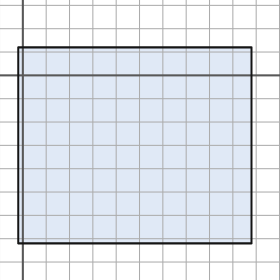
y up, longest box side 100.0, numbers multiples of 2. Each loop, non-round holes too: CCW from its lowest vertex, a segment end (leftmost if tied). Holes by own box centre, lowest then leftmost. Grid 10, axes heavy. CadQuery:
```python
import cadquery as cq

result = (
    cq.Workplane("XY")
    .moveTo(-2.0, -72.0)
    .lineTo(98.0, -72.0)
    .lineTo(98.0, 12.0)
    .lineTo(-2.0, 12.0)
    .close()
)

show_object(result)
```